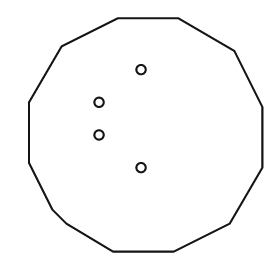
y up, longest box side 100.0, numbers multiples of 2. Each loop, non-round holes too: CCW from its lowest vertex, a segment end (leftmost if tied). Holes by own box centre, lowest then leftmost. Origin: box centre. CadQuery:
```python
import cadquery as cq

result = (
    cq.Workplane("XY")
    .moveTo(-14.0, -50.0)
    .lineTo(12.0, -50.0)
    .lineTo(36.0, -38.0)
    .lineTo(50.0, -14.0)
    .lineTo(50.0, 12.0)
    .lineTo(38.0, 36.0)
    .lineTo(14.0, 50.0)
    .lineTo(-12.0, 50.0)
    .lineTo(-36.0, 38.0)
    .lineTo(-50.0, 14.0)
    .lineTo(-50.0, -12.0)
    .lineTo(-40.0, -32.0)
    .lineTo(-34.0, -38.0)
    .close()
    .moveTo(-2.0, -14.0)
    .circle(2.0)
    .moveTo(-20.0, 0.0)
    .circle(2.0)
    .moveTo(-20.0, 14.0)
    .circle(2.0)
    .moveTo(-2.0, 28.0)
    .circle(2.0)
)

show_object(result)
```